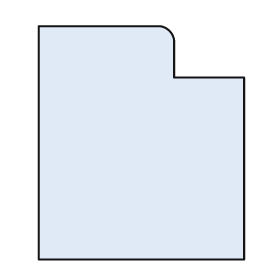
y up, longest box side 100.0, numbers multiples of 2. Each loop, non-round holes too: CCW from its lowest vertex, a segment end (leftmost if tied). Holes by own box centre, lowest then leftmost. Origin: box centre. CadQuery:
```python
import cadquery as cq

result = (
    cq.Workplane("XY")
    .moveTo(-44.0, -50.0)
    .lineTo(44.0, -50.0)
    .lineTo(44.0, 28.0)
    .lineTo(14.0, 28.0)
    .lineTo(14.0, 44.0)
    .threePointArc((12.0, 48.0), (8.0, 50.0))
    .lineTo(-44.0, 50.0)
    .close()
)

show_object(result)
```